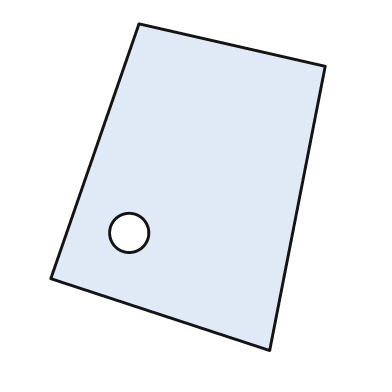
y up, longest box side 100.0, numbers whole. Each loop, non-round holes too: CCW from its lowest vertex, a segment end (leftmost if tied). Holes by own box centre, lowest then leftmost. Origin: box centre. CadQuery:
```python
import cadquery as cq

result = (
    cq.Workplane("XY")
    .moveTo(25.0, -50.0)
    .lineTo(42.0, 37.0)
    .lineTo(-15.0, 50.0)
    .lineTo(-42.0, -28.0)
    .close()
    .moveTo(-18.0, -14.0)
    .circle(6.0)
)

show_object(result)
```